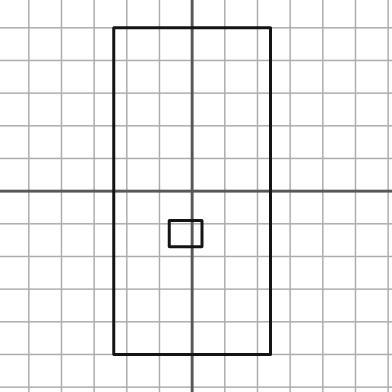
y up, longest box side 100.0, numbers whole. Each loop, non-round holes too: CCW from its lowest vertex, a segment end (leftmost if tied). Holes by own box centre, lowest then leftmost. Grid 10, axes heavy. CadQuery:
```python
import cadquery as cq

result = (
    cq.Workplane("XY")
    .moveTo(-24.0, -50.0)
    .lineTo(24.0, -50.0)
    .lineTo(24.0, 50.0)
    .lineTo(-24.0, 50.0)
    .close()
    .moveTo(-7.0, -17.0)
    .lineTo(3.0, -17.0)
    .lineTo(3.0, -9.0)
    .lineTo(-7.0, -9.0)
    .close()
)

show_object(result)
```